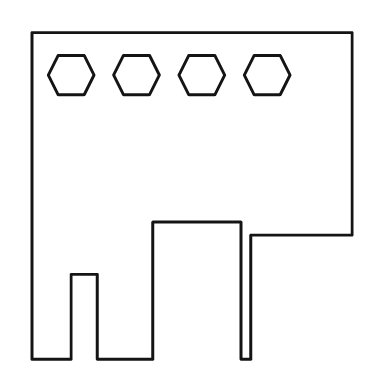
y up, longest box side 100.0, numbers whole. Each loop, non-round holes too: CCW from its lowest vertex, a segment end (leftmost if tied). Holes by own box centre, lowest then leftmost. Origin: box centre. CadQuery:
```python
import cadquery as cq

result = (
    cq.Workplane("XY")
    .moveTo(-49.0, -50.0)
    .lineTo(-37.0, -50.0)
    .lineTo(-37.0, -24.0)
    .lineTo(-29.0, -24.0)
    .lineTo(-29.0, -50.0)
    .lineTo(-12.0, -50.0)
    .lineTo(-12.0, -8.0)
    .lineTo(15.0, -8.0)
    .lineTo(15.0, -50.0)
    .lineTo(18.0, -50.0)
    .lineTo(18.0, -12.0)
    .lineTo(49.0, -12.0)
    .lineTo(49.0, 50.0)
    .lineTo(-49.0, 50.0)
    .close()
    .moveTo(-41.0, 31.0)
    .lineTo(-33.0, 31.0)
    .lineTo(-30.0, 37.0)
    .lineTo(-33.0, 43.0)
    .lineTo(-41.0, 43.0)
    .lineTo(-44.0, 37.0)
    .close()
    .moveTo(-21.0, 31.0)
    .lineTo(-13.0, 31.0)
    .lineTo(-10.0, 37.0)
    .lineTo(-13.0, 43.0)
    .lineTo(-21.0, 43.0)
    .lineTo(-24.0, 37.0)
    .close()
    .moveTo(-1.0, 31.0)
    .lineTo(7.0, 31.0)
    .lineTo(10.0, 37.0)
    .lineTo(7.0, 43.0)
    .lineTo(-1.0, 43.0)
    .lineTo(-4.0, 37.0)
    .close()
    .moveTo(19.0, 31.0)
    .lineTo(27.0, 31.0)
    .lineTo(30.0, 37.0)
    .lineTo(27.0, 43.0)
    .lineTo(19.0, 43.0)
    .lineTo(16.0, 37.0)
    .close()
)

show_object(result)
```